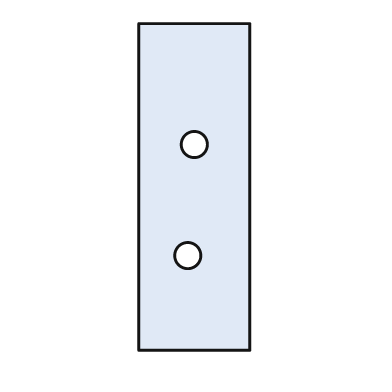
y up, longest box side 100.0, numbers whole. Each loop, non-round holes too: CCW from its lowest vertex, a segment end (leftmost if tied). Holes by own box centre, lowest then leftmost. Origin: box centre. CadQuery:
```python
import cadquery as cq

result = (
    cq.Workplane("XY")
    .moveTo(-17.0, -50.0)
    .lineTo(17.0, -50.0)
    .lineTo(17.0, 50.0)
    .lineTo(-17.0, 50.0)
    .close()
    .moveTo(-2.0, -21.0)
    .circle(4.0)
    .moveTo(0.0, 13.0)
    .circle(4.0)
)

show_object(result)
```